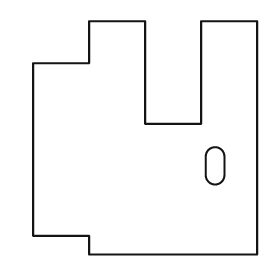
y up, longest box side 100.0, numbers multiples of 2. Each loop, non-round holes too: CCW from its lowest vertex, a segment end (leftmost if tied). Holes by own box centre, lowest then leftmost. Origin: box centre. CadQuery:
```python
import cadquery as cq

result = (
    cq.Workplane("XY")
    .moveTo(-24.0, -50.0)
    .lineTo(48.0, -50.0)
    .lineTo(48.0, 50.0)
    .lineTo(24.0, 50.0)
    .lineTo(24.0, 6.0)
    .lineTo(0.0, 6.0)
    .lineTo(0.0, 50.0)
    .lineTo(-24.0, 50.0)
    .lineTo(-24.0, 32.0)
    .lineTo(-48.0, 32.0)
    .lineTo(-48.0, -42.0)
    .lineTo(-24.0, -42.0)
    .close()
    .moveTo(26.0, -16.0)
    .threePointArc((30.0, -20.0), (34.0, -16.0))
    .lineTo(34.0, -8.0)
    .threePointArc((30.0, -4.0), (26.0, -8.0))
    .close()
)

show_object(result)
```